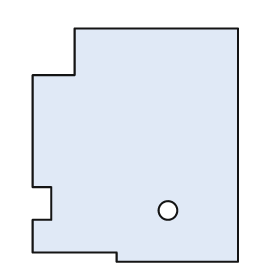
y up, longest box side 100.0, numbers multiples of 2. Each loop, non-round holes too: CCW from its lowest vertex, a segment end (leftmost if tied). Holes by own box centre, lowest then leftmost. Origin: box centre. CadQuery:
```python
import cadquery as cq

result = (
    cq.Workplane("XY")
    .moveTo(-8.0, -50.0)
    .lineTo(44.0, -50.0)
    .lineTo(44.0, 50.0)
    .lineTo(-26.0, 50.0)
    .lineTo(-26.0, 30.0)
    .lineTo(-44.0, 30.0)
    .lineTo(-44.0, -18.0)
    .lineTo(-36.0, -18.0)
    .lineTo(-36.0, -32.0)
    .lineTo(-44.0, -32.0)
    .lineTo(-44.0, -46.0)
    .lineTo(-8.0, -46.0)
    .close()
    .moveTo(14.0, -28.0)
    .circle(4.0)
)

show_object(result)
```